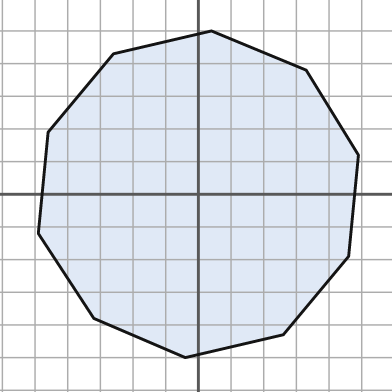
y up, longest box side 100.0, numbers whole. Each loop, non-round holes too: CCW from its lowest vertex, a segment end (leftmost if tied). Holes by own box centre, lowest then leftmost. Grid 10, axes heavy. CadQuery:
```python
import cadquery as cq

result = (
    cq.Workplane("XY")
    .moveTo(-4.0, -50.0)
    .lineTo(26.0, -43.0)
    .lineTo(46.0, -19.0)
    .lineTo(49.0, 12.0)
    .lineTo(33.0, 38.0)
    .lineTo(4.0, 50.0)
    .lineTo(-26.0, 43.0)
    .lineTo(-46.0, 19.0)
    .lineTo(-49.0, -12.0)
    .lineTo(-32.0, -38.0)
    .close()
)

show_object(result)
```